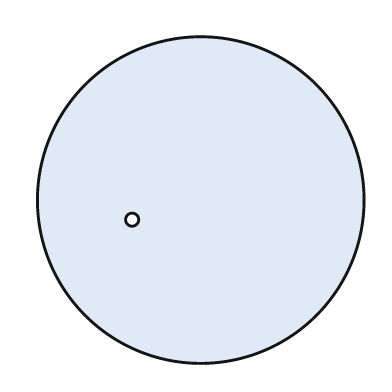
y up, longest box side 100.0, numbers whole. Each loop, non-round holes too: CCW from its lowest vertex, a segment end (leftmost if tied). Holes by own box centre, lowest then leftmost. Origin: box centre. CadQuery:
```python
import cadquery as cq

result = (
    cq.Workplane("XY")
    .moveTo(0.0, 0.0)
    .circle(50.0)
    .moveTo(-21.0, -6.0)
    .circle(2.0)
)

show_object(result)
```